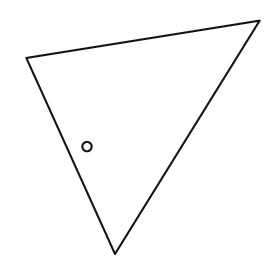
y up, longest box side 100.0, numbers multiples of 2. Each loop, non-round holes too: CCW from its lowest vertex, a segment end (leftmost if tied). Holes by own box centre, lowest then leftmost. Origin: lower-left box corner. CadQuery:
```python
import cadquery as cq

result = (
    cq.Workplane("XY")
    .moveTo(38.0, 0.0)
    .lineTo(100.0, 100.0)
    .lineTo(0.0, 84.0)
    .close()
    .moveTo(26.0, 46.0)
    .circle(2.0)
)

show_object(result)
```